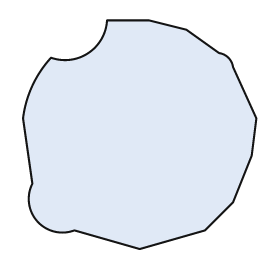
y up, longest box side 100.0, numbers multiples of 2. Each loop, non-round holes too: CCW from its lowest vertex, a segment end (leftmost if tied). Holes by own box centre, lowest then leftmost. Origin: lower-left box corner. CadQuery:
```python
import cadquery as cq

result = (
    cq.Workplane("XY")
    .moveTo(50.0, 0.0)
    .lineTo(78.0, 8.0)
    .lineTo(90.0, 20.0)
    .lineTo(98.0, 40.0)
    .lineTo(100.0, 56.0)
    .lineTo(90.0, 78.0)
    .threePointArc((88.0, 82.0), (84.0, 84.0))
    .lineTo(70.0, 94.0)
    .lineTo(54.0, 98.0)
    .lineTo(36.0, 98.0)
    .threePointArc((28.0, 84.0), (12.0, 82.0))
    .threePointArc((4.0, 70.0), (0.0, 56.0))
    .lineTo(4.0, 28.0)
    .threePointArc((6.0, 12.0), (22.0, 8.0))
    .close()
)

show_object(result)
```